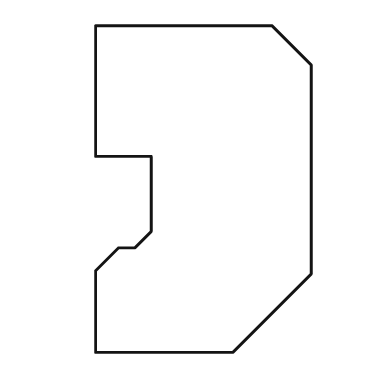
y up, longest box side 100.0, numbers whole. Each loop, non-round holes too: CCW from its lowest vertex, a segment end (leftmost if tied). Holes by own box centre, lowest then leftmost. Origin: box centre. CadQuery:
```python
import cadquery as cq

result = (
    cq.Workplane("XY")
    .moveTo(-33.0, -50.0)
    .lineTo(9.0, -50.0)
    .lineTo(33.0, -26.0)
    .lineTo(33.0, 38.0)
    .lineTo(21.0, 50.0)
    .lineTo(-33.0, 50.0)
    .lineTo(-33.0, 10.0)
    .lineTo(-16.0, 10.0)
    .lineTo(-16.0, -13.0)
    .lineTo(-21.0, -18.0)
    .lineTo(-26.0, -18.0)
    .lineTo(-33.0, -25.0)
    .close()
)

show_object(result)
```